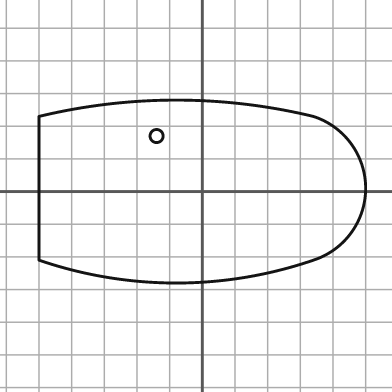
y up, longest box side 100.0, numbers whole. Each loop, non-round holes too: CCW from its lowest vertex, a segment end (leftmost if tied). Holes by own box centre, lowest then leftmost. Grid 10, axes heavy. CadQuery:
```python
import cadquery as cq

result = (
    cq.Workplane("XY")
    .moveTo(-50.0, -21.0)
    .threePointArc((-8.0, -28.0), (34.0, -21.0))
    .threePointArc((50.0, 1.0), (34.0, 23.0))
    .threePointArc((-8.0, 28.0), (-50.0, 23.0))
    .close()
    .moveTo(-14.0, 17.0)
    .circle(2.0)
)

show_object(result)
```